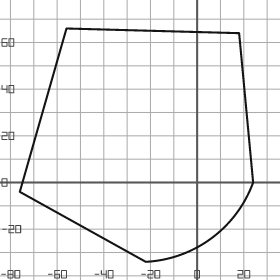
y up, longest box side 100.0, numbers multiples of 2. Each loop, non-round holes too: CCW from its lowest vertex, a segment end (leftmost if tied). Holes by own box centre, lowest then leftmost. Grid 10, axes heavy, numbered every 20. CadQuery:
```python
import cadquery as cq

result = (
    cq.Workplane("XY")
    .moveTo(-22.0, -34.0)
    .threePointArc((6.0, -24.0), (24.0, 0.0))
    .lineTo(18.0, 64.0)
    .lineTo(-56.0, 66.0)
    .lineTo(-76.0, -4.0)
    .close()
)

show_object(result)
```